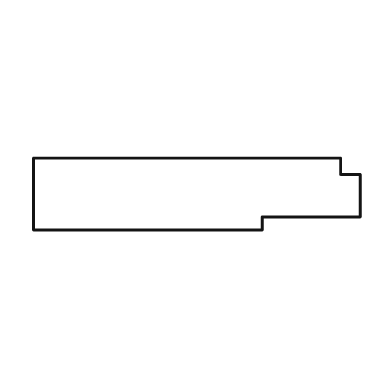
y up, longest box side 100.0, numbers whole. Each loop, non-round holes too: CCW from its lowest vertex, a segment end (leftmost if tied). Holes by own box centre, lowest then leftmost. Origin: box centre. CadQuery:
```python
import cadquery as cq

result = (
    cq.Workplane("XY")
    .moveTo(-50.0, -11.0)
    .lineTo(20.0, -11.0)
    .lineTo(20.0, -7.0)
    .lineTo(50.0, -7.0)
    .lineTo(50.0, 6.0)
    .lineTo(44.0, 6.0)
    .lineTo(44.0, 11.0)
    .lineTo(-50.0, 11.0)
    .close()
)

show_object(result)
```